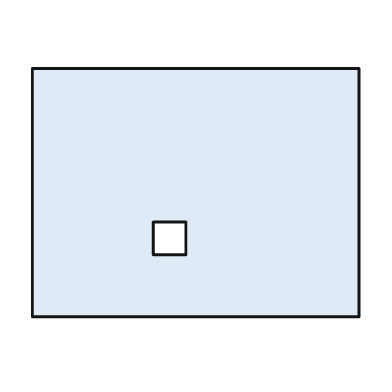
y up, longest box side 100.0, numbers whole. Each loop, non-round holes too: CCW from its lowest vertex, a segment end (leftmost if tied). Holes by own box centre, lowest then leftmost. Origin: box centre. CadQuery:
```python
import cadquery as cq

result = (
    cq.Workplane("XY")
    .moveTo(-50.0, -38.0)
    .lineTo(50.0, -38.0)
    .lineTo(50.0, 38.0)
    .lineTo(-50.0, 38.0)
    .close()
    .moveTo(-13.0, -19.0)
    .lineTo(-3.0, -19.0)
    .lineTo(-3.0, -9.0)
    .lineTo(-13.0, -9.0)
    .close()
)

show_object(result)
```